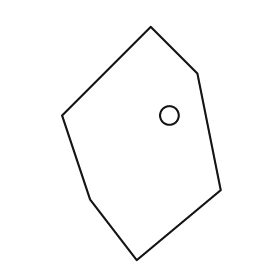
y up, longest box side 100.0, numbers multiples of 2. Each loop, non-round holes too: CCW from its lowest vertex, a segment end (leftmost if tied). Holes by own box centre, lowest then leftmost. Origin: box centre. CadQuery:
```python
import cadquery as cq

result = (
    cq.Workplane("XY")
    .moveTo(-2.0, -50.0)
    .lineTo(34.0, -20.0)
    .lineTo(24.0, 30.0)
    .lineTo(4.0, 50.0)
    .lineTo(-34.0, 12.0)
    .lineTo(-22.0, -24.0)
    .close()
    .moveTo(12.0, 12.0)
    .circle(4.0)
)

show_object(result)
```